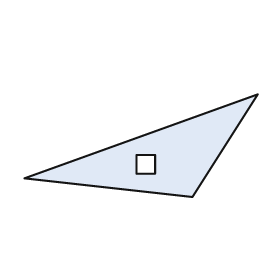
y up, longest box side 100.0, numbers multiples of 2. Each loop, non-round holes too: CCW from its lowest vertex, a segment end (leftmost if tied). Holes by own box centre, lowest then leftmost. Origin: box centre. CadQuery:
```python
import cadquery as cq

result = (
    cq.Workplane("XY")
    .moveTo(22.0, -22.0)
    .lineTo(50.0, 22.0)
    .lineTo(-50.0, -14.0)
    .close()
    .moveTo(-2.0, -12.0)
    .lineTo(6.0, -12.0)
    .lineTo(6.0, -4.0)
    .lineTo(-2.0, -4.0)
    .close()
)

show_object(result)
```